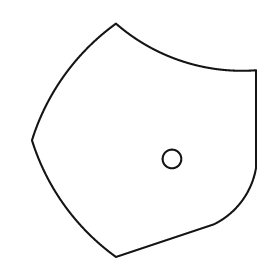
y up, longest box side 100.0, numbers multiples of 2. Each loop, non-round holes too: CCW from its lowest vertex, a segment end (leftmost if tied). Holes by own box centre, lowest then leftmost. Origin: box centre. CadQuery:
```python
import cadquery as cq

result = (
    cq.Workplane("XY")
    .moveTo(-12.0, -50.0)
    .lineTo(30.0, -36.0)
    .threePointArc((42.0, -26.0), (48.0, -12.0))
    .lineTo(48.0, 30.0)
    .threePointArc((16.0, 34.0), (-12.0, 50.0))
    .threePointArc((-34.0, 28.0), (-48.0, 0.0))
    .threePointArc((-34.0, -28.0), (-12.0, -50.0))
    .close()
    .moveTo(12.0, -8.0)
    .circle(4.0)
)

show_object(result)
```